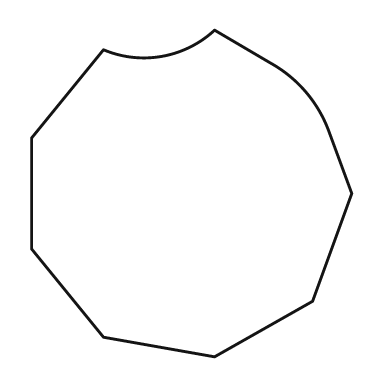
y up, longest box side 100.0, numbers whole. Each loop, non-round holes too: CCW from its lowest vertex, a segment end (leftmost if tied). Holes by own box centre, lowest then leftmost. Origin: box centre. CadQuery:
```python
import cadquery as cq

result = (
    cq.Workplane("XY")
    .moveTo(7.0, -50.0)
    .lineTo(37.0, -33.0)
    .lineTo(49.0, 0.0)
    .lineTo(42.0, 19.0)
    .threePointArc((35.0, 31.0), (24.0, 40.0))
    .lineTo(7.0, 50.0)
    .threePointArc((-9.0, 42.0), (-27.0, 44.0))
    .lineTo(-49.0, 17.0)
    .lineTo(-49.0, -17.0)
    .lineTo(-27.0, -44.0)
    .close()
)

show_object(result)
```